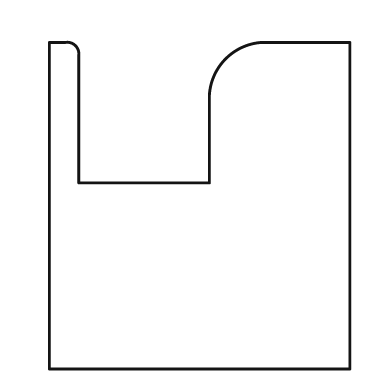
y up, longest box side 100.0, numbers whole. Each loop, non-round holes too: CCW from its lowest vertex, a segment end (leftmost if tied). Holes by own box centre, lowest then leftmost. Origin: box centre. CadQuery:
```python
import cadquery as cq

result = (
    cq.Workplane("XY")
    .moveTo(-46.0, -50.0)
    .lineTo(46.0, -50.0)
    .lineTo(46.0, 50.0)
    .lineTo(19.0, 50.0)
    .threePointArc((8.0, 45.0), (3.0, 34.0))
    .lineTo(3.0, 7.0)
    .lineTo(-37.0, 7.0)
    .lineTo(-37.0, 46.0)
    .threePointArc((-38.0, 49.0), (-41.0, 50.0))
    .lineTo(-46.0, 50.0)
    .close()
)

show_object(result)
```